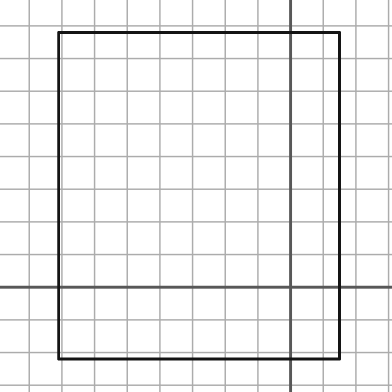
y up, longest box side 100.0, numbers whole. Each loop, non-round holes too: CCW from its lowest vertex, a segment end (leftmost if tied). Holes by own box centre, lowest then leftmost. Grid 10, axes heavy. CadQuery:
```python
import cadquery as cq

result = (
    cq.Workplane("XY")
    .moveTo(-71.0, -22.0)
    .lineTo(15.0, -22.0)
    .lineTo(15.0, 78.0)
    .lineTo(-71.0, 78.0)
    .close()
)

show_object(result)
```